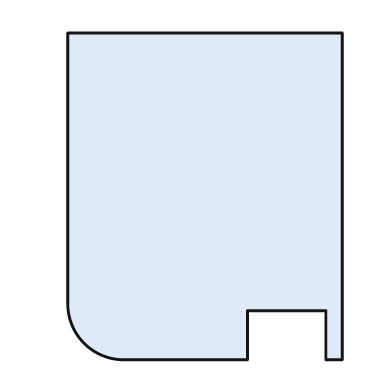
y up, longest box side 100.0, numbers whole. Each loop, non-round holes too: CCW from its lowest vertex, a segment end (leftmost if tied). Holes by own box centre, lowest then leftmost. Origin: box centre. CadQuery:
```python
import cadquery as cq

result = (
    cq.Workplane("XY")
    .moveTo(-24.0, -50.0)
    .lineTo(13.0, -50.0)
    .lineTo(13.0, -35.0)
    .lineTo(37.0, -35.0)
    .lineTo(37.0, -50.0)
    .lineTo(42.0, -50.0)
    .lineTo(42.0, 50.0)
    .lineTo(-42.0, 50.0)
    .lineTo(-42.0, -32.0)
    .threePointArc((-37.0, -45.0), (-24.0, -50.0))
    .close()
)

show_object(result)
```